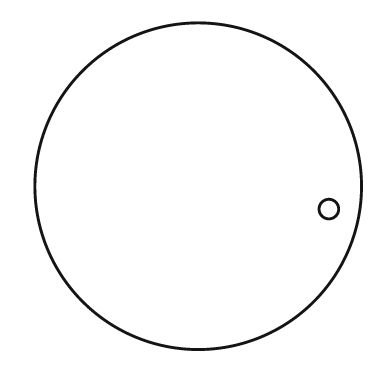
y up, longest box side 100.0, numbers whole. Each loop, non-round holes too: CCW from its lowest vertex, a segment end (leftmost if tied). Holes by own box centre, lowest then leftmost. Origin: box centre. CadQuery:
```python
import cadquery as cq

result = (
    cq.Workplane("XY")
    .moveTo(0.0, 0.0)
    .circle(50.0)
    .moveTo(40.0, -7.0)
    .circle(3.0)
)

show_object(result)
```